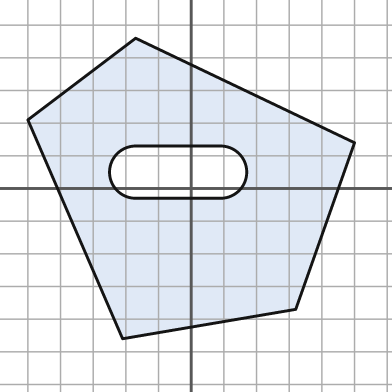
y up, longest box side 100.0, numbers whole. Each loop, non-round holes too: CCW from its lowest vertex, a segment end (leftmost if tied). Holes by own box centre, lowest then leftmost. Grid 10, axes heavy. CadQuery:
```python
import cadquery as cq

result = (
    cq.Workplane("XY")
    .moveTo(-21.0, -46.0)
    .lineTo(32.0, -37.0)
    .lineTo(50.0, 14.0)
    .lineTo(-17.0, 46.0)
    .lineTo(-50.0, 21.0)
    .close()
    .moveTo(-17.0, -3.0)
    .lineTo(9.0, -3.0)
    .threePointArc((17.0, 5.0), (9.0, 13.0))
    .lineTo(-17.0, 13.0)
    .threePointArc((-25.0, 5.0), (-17.0, -3.0))
    .close()
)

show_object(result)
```